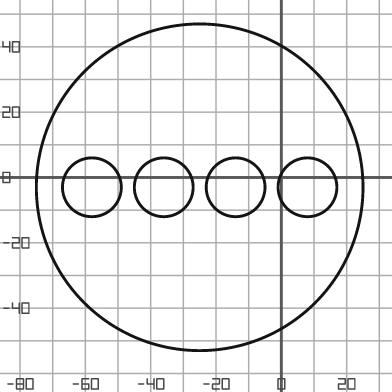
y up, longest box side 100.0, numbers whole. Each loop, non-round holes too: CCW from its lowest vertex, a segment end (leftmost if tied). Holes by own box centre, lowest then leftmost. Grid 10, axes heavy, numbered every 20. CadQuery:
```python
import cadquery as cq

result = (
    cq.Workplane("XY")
    .moveTo(-25.0, -3.0)
    .circle(50.0)
    .moveTo(-58.0, -3.0)
    .circle(9.0)
    .moveTo(-36.0, -3.0)
    .circle(9.0)
    .moveTo(-14.0, -3.0)
    .circle(9.0)
    .moveTo(8.0, -3.0)
    .circle(9.0)
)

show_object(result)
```